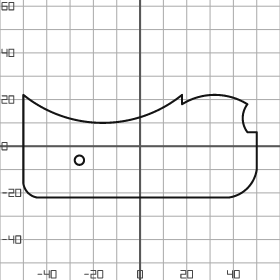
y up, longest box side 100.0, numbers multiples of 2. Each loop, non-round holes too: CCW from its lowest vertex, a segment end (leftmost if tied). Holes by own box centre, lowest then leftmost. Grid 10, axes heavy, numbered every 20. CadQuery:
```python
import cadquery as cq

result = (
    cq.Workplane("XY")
    .moveTo(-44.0, -22.0)
    .lineTo(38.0, -22.0)
    .threePointArc((46.0, -18.0), (50.0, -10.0))
    .lineTo(50.0, 6.0)
    .lineTo(46.0, 6.0)
    .threePointArc((44.0, 12.0), (46.0, 18.0))
    .threePointArc((32.0, 22.0), (18.0, 18.0))
    .lineTo(18.0, 22.0)
    .threePointArc((-16.0, 10.0), (-50.0, 22.0))
    .lineTo(-50.0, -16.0)
    .threePointArc((-48.0, -20.0), (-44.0, -22.0))
    .close()
    .moveTo(-26.0, -6.0)
    .circle(2.0)
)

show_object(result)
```